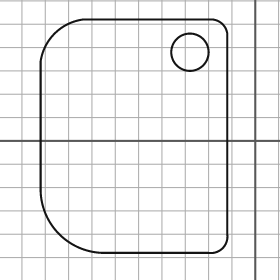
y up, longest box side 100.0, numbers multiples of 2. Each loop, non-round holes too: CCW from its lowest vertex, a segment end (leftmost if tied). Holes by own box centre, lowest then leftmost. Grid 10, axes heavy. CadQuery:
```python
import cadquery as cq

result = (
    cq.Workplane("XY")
    .moveTo(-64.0, -48.0)
    .lineTo(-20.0, -48.0)
    .threePointArc((-14.0, -46.0), (-12.0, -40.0))
    .lineTo(-12.0, 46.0)
    .threePointArc((-14.0, 50.0), (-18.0, 52.0))
    .lineTo(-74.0, 52.0)
    .threePointArc((-86.0, 46.0), (-92.0, 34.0))
    .lineTo(-92.0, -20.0)
    .threePointArc((-84.0, -40.0), (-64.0, -48.0))
    .close()
    .moveTo(-28.0, 38.0)
    .circle(8.0)
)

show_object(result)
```